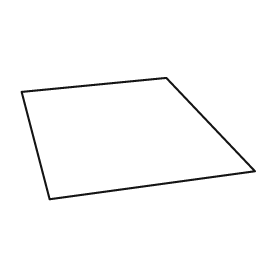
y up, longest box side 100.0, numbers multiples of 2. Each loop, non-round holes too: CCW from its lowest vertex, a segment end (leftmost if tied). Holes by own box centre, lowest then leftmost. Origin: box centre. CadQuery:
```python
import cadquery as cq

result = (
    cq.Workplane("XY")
    .moveTo(-38.0, -26.0)
    .lineTo(50.0, -14.0)
    .lineTo(12.0, 26.0)
    .lineTo(-50.0, 20.0)
    .close()
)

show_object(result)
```